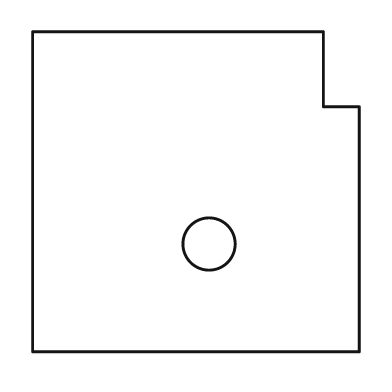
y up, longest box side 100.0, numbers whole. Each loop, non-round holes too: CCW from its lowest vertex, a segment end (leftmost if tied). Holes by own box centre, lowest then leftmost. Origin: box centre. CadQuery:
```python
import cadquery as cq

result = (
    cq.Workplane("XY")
    .moveTo(-50.0, -49.0)
    .lineTo(50.0, -49.0)
    .lineTo(50.0, 26.0)
    .lineTo(39.0, 26.0)
    .lineTo(39.0, 49.0)
    .lineTo(-50.0, 49.0)
    .close()
    .moveTo(4.0, -16.0)
    .circle(8.0)
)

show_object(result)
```